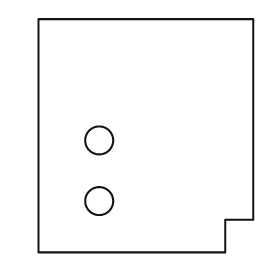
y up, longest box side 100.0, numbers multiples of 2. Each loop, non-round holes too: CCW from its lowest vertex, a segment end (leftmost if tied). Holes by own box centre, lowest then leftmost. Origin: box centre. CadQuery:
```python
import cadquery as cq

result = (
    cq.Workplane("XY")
    .moveTo(-46.0, -50.0)
    .lineTo(34.0, -50.0)
    .lineTo(34.0, -36.0)
    .lineTo(46.0, -36.0)
    .lineTo(46.0, 50.0)
    .lineTo(-46.0, 50.0)
    .close()
    .moveTo(-20.0, -28.0)
    .circle(6.0)
    .moveTo(-20.0, -2.0)
    .circle(6.0)
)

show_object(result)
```